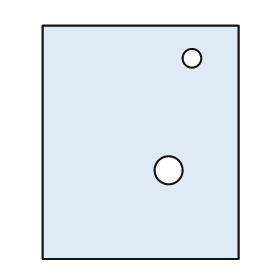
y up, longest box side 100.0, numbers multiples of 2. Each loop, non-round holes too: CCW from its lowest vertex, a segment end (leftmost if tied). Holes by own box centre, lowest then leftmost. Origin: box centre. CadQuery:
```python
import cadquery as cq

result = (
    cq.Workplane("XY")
    .moveTo(-42.0, -50.0)
    .lineTo(42.0, -50.0)
    .lineTo(42.0, 50.0)
    .lineTo(-42.0, 50.0)
    .close()
    .moveTo(12.0, -12.0)
    .circle(6.0)
    .moveTo(22.0, 36.0)
    .circle(4.0)
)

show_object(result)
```